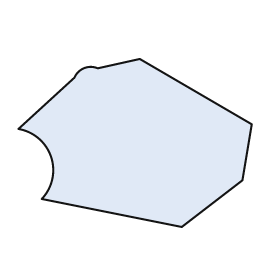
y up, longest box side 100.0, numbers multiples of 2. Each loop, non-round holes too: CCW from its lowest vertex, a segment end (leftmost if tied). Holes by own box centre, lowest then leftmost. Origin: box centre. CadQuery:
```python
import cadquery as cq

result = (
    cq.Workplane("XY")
    .moveTo(20.0, -36.0)
    .lineTo(46.0, -16.0)
    .lineTo(50.0, 8.0)
    .lineTo(2.0, 36.0)
    .lineTo(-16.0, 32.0)
    .threePointArc((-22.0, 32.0), (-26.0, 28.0))
    .lineTo(-50.0, 6.0)
    .threePointArc((-36.0, -6.0), (-40.0, -24.0))
    .close()
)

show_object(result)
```